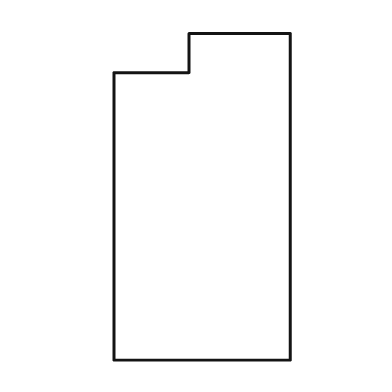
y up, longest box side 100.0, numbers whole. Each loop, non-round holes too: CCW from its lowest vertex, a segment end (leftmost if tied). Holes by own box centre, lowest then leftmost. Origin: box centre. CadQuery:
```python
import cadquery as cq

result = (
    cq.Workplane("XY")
    .moveTo(-27.0, -50.0)
    .lineTo(27.0, -50.0)
    .lineTo(27.0, 50.0)
    .lineTo(-4.0, 50.0)
    .lineTo(-4.0, 38.0)
    .lineTo(-27.0, 38.0)
    .close()
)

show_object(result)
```